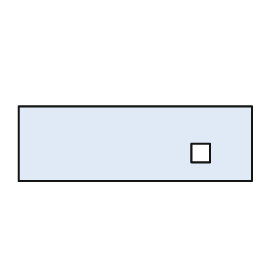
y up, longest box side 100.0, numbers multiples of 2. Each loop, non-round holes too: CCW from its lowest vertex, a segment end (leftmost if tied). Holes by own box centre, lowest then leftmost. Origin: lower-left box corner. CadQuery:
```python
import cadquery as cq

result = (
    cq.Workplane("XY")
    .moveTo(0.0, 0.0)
    .lineTo(100.0, 0.0)
    .lineTo(100.0, 32.0)
    .lineTo(0.0, 32.0)
    .close()
    .moveTo(74.0, 8.0)
    .lineTo(82.0, 8.0)
    .lineTo(82.0, 16.0)
    .lineTo(74.0, 16.0)
    .close()
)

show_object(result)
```